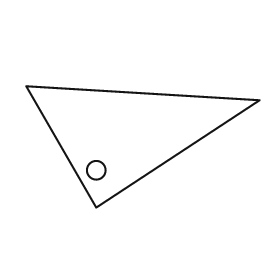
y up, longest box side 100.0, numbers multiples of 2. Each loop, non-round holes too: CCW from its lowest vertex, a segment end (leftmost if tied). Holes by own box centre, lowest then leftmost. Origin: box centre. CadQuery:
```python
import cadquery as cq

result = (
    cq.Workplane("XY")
    .moveTo(-20.0, -26.0)
    .lineTo(50.0, 20.0)
    .lineTo(-50.0, 26.0)
    .close()
    .moveTo(-20.0, -10.0)
    .circle(4.0)
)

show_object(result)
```